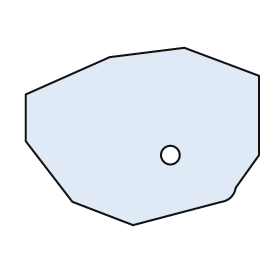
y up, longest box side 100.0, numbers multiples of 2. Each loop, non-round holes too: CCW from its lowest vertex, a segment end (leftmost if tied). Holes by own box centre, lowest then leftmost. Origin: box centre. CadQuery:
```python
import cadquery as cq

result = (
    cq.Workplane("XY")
    .moveTo(-4.0, -38.0)
    .lineTo(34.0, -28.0)
    .threePointArc((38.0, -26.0), (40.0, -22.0))
    .lineTo(50.0, -8.0)
    .lineTo(50.0, 26.0)
    .lineTo(18.0, 38.0)
    .lineTo(-14.0, 34.0)
    .lineTo(-50.0, 18.0)
    .lineTo(-50.0, -2.0)
    .lineTo(-30.0, -28.0)
    .close()
    .moveTo(12.0, -8.0)
    .circle(4.0)
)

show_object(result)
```